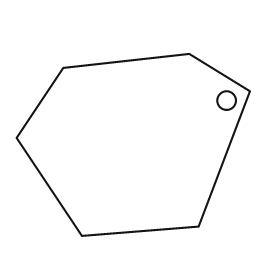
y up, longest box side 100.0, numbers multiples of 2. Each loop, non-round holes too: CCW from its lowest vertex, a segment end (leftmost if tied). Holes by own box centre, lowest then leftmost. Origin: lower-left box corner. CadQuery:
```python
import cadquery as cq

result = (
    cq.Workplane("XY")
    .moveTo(28.0, 0.0)
    .lineTo(78.0, 4.0)
    .lineTo(100.0, 62.0)
    .lineTo(74.0, 78.0)
    .lineTo(20.0, 72.0)
    .lineTo(0.0, 42.0)
    .close()
    .moveTo(90.0, 58.0)
    .circle(4.0)
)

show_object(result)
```